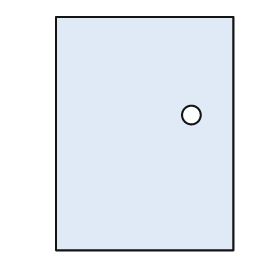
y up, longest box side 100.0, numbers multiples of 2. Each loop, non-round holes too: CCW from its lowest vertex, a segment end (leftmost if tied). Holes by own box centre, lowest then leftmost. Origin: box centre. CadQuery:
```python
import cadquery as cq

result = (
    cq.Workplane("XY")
    .moveTo(-38.0, -50.0)
    .lineTo(38.0, -50.0)
    .lineTo(38.0, 50.0)
    .lineTo(-38.0, 50.0)
    .close()
    .moveTo(20.0, 8.0)
    .circle(4.0)
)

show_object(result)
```